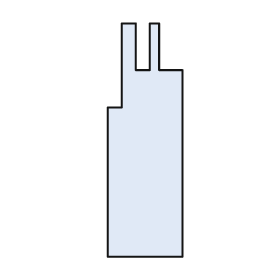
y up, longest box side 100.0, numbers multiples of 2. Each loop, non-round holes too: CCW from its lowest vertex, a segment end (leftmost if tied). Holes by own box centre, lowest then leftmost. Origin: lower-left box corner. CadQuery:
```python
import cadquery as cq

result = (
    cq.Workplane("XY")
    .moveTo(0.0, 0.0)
    .lineTo(32.0, 0.0)
    .lineTo(32.0, 80.0)
    .lineTo(22.0, 80.0)
    .lineTo(22.0, 100.0)
    .lineTo(18.0, 100.0)
    .lineTo(18.0, 80.0)
    .lineTo(12.0, 80.0)
    .lineTo(12.0, 100.0)
    .lineTo(6.0, 100.0)
    .lineTo(6.0, 64.0)
    .lineTo(0.0, 64.0)
    .close()
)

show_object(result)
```